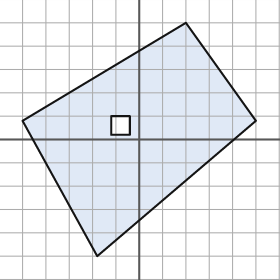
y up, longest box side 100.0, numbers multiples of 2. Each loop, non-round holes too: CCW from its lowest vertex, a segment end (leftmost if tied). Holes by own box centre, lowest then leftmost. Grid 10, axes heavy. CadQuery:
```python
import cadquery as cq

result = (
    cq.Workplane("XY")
    .moveTo(-18.0, -50.0)
    .lineTo(50.0, 8.0)
    .lineTo(20.0, 50.0)
    .lineTo(-50.0, 8.0)
    .close()
    .moveTo(-12.0, 2.0)
    .lineTo(-4.0, 2.0)
    .lineTo(-4.0, 10.0)
    .lineTo(-12.0, 10.0)
    .close()
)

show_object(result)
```